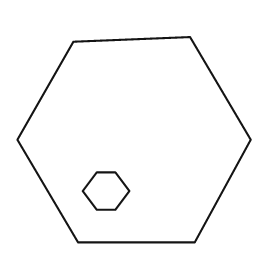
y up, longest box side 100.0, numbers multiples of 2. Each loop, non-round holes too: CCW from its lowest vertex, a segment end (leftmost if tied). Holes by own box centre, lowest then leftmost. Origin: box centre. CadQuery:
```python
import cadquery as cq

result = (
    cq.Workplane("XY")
    .moveTo(-24.0, -44.0)
    .lineTo(26.0, -44.0)
    .lineTo(50.0, 0.0)
    .lineTo(24.0, 44.0)
    .lineTo(-26.0, 42.0)
    .lineTo(-50.0, 0.0)
    .close()
    .moveTo(-16.0, -30.0)
    .lineTo(-8.0, -30.0)
    .lineTo(-2.0, -22.0)
    .lineTo(-8.0, -14.0)
    .lineTo(-16.0, -14.0)
    .lineTo(-22.0, -22.0)
    .close()
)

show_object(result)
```